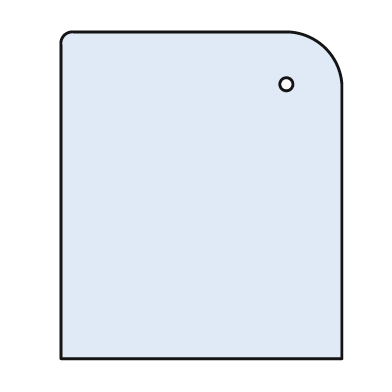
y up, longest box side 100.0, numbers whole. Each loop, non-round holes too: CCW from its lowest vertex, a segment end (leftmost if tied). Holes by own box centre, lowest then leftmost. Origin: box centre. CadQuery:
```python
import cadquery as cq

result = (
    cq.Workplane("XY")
    .moveTo(-43.0, -50.0)
    .lineTo(43.0, -50.0)
    .lineTo(43.0, 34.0)
    .threePointArc((38.0, 45.0), (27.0, 50.0))
    .lineTo(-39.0, 50.0)
    .threePointArc((-42.0, 49.0), (-43.0, 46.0))
    .close()
    .moveTo(26.0, 34.0)
    .circle(2.0)
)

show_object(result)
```